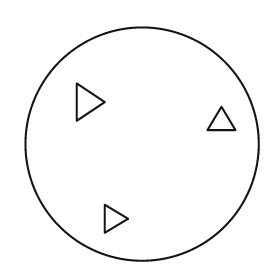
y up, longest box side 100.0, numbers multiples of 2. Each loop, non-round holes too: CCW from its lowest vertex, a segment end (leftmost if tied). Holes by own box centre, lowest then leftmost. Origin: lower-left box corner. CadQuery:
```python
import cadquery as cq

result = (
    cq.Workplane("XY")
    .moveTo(50.0, 50.0)
    .circle(50.0)
    .moveTo(34.0, 12.0)
    .lineTo(44.0, 18.0)
    .lineTo(34.0, 24.0)
    .close()
    .moveTo(78.0, 56.0)
    .lineTo(90.0, 56.0)
    .lineTo(84.0, 66.0)
    .close()
    .moveTo(22.0, 60.0)
    .lineTo(34.0, 68.0)
    .lineTo(22.0, 76.0)
    .close()
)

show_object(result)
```